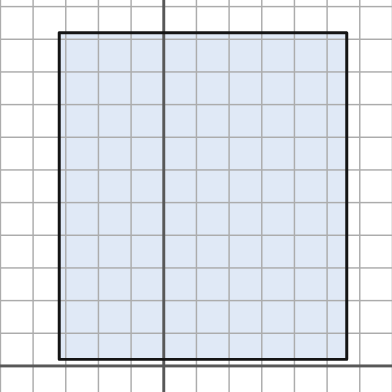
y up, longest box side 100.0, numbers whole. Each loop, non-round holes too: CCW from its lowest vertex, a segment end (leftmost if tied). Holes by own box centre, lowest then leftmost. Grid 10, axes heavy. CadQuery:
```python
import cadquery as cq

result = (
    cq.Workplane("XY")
    .moveTo(-32.0, 2.0)
    .lineTo(56.0, 2.0)
    .lineTo(56.0, 102.0)
    .lineTo(-32.0, 102.0)
    .close()
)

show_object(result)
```